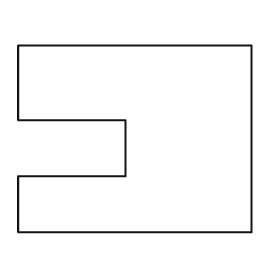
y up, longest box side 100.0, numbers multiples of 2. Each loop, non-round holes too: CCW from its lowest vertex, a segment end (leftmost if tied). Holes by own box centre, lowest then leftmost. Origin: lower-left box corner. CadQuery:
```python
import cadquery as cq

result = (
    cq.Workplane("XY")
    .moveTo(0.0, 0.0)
    .lineTo(100.0, 0.0)
    .lineTo(100.0, 80.0)
    .lineTo(0.0, 80.0)
    .lineTo(0.0, 48.0)
    .lineTo(46.0, 48.0)
    .lineTo(46.0, 24.0)
    .lineTo(0.0, 24.0)
    .close()
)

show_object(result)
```